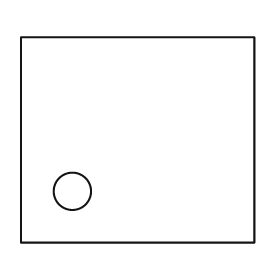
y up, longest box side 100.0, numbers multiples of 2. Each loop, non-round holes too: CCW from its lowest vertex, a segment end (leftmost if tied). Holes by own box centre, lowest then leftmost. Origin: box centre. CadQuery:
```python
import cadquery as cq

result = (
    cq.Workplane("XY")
    .moveTo(-50.0, -44.0)
    .lineTo(50.0, -44.0)
    .lineTo(50.0, 44.0)
    .lineTo(-50.0, 44.0)
    .close()
    .moveTo(-28.0, -22.0)
    .circle(8.0)
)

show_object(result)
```